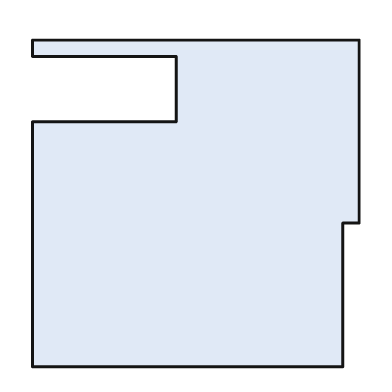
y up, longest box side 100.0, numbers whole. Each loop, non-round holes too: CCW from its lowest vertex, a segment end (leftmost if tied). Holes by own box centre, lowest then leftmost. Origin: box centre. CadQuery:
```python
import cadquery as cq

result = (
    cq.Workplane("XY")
    .moveTo(-50.0, -50.0)
    .lineTo(45.0, -50.0)
    .lineTo(45.0, -6.0)
    .lineTo(50.0, -6.0)
    .lineTo(50.0, 50.0)
    .lineTo(-50.0, 50.0)
    .lineTo(-50.0, 45.0)
    .lineTo(-6.0, 45.0)
    .lineTo(-6.0, 25.0)
    .lineTo(-50.0, 25.0)
    .close()
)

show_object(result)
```